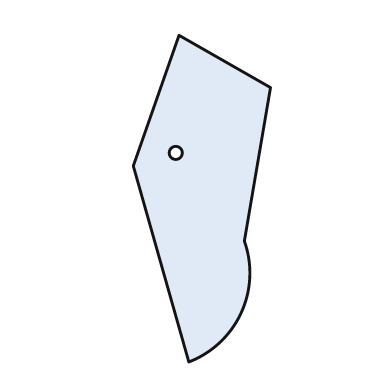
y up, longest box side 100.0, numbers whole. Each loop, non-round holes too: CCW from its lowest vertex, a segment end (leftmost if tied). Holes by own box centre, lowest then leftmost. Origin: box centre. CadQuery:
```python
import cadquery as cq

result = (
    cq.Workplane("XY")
    .moveTo(-4.0, -50.0)
    .threePointArc((12.0, -35.0), (13.0, -13.0))
    .lineTo(21.0, 34.0)
    .lineTo(-7.0, 50.0)
    .lineTo(-21.0, 10.0)
    .close()
    .moveTo(-8.0, 14.0)
    .circle(2.0)
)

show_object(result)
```